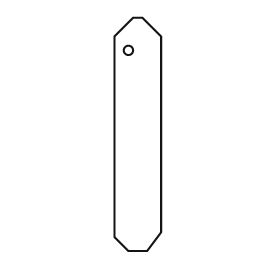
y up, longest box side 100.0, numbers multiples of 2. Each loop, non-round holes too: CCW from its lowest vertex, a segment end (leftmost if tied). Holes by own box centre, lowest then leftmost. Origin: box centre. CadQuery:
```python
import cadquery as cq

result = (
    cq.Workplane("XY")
    .moveTo(-4.0, -50.0)
    .lineTo(4.0, -50.0)
    .lineTo(10.0, -42.0)
    .lineTo(10.0, 42.0)
    .lineTo(2.0, 50.0)
    .lineTo(-2.0, 50.0)
    .lineTo(-10.0, 42.0)
    .lineTo(-10.0, -44.0)
    .close()
    .moveTo(-4.0, 36.0)
    .circle(2.0)
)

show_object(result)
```